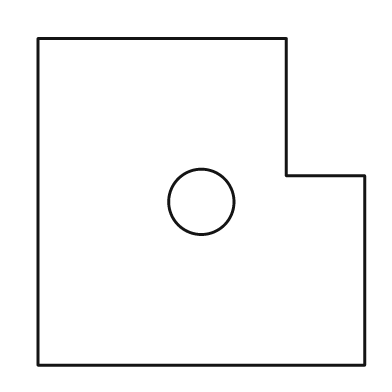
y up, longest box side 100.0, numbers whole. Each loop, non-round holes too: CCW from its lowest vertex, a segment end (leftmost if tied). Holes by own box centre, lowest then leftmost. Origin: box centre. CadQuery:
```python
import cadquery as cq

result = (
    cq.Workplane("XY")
    .moveTo(-50.0, -50.0)
    .lineTo(50.0, -50.0)
    .lineTo(50.0, 8.0)
    .lineTo(26.0, 8.0)
    .lineTo(26.0, 50.0)
    .lineTo(-50.0, 50.0)
    .close()
    .moveTo(0.0, 0.0)
    .circle(10.0)
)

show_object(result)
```